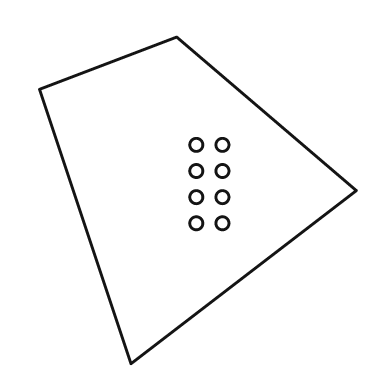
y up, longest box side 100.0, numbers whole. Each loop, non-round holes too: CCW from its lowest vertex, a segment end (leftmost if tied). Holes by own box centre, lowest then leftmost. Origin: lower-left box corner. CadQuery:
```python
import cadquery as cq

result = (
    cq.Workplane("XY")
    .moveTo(28.0, 0.0)
    .lineTo(97.0, 53.0)
    .lineTo(42.0, 100.0)
    .lineTo(0.0, 84.0)
    .close()
    .moveTo(48.0, 43.0)
    .circle(2.0)
    .moveTo(56.0, 43.0)
    .circle(2.0)
    .moveTo(48.0, 51.0)
    .circle(2.0)
    .moveTo(56.0, 51.0)
    .circle(2.0)
    .moveTo(48.0, 59.0)
    .circle(2.0)
    .moveTo(56.0, 59.0)
    .circle(2.0)
    .moveTo(48.0, 67.0)
    .circle(2.0)
    .moveTo(56.0, 67.0)
    .circle(2.0)
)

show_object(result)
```